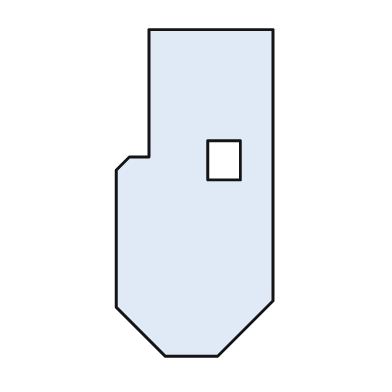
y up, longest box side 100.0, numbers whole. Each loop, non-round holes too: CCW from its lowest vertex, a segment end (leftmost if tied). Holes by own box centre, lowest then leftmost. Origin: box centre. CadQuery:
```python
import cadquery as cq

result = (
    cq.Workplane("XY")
    .moveTo(-9.0, -50.0)
    .lineTo(7.0, -50.0)
    .lineTo(24.0, -33.0)
    .lineTo(24.0, 50.0)
    .lineTo(-14.0, 50.0)
    .lineTo(-14.0, 11.0)
    .lineTo(-20.0, 11.0)
    .lineTo(-24.0, 7.0)
    .lineTo(-24.0, -35.0)
    .close()
    .moveTo(4.0, 4.0)
    .lineTo(14.0, 4.0)
    .lineTo(14.0, 16.0)
    .lineTo(4.0, 16.0)
    .close()
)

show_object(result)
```